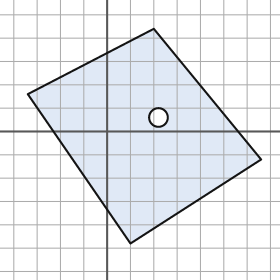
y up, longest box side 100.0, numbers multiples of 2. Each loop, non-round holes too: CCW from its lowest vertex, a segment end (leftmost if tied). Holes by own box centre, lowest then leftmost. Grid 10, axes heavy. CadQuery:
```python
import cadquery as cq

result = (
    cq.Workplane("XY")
    .moveTo(10.0, -48.0)
    .lineTo(66.0, -12.0)
    .lineTo(20.0, 44.0)
    .lineTo(-34.0, 16.0)
    .close()
    .moveTo(22.0, 6.0)
    .circle(4.0)
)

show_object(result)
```